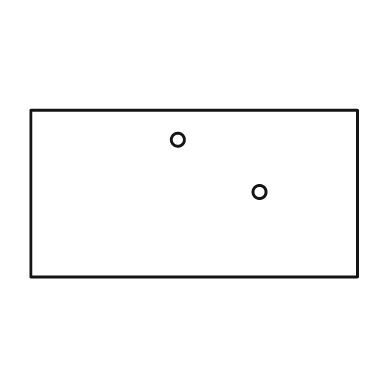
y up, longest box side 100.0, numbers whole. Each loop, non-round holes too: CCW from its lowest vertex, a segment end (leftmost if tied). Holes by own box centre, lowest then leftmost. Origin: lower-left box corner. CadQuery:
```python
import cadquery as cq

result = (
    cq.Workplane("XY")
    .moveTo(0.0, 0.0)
    .lineTo(100.0, 0.0)
    .lineTo(100.0, 51.0)
    .lineTo(0.0, 51.0)
    .close()
    .moveTo(70.0, 26.0)
    .circle(2.0)
    .moveTo(45.0, 42.0)
    .circle(2.0)
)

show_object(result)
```